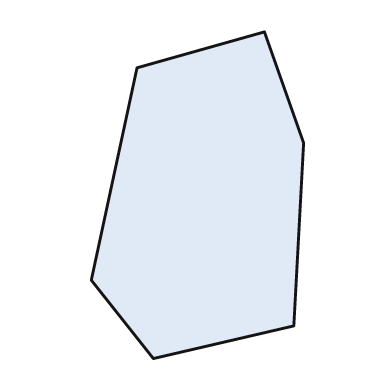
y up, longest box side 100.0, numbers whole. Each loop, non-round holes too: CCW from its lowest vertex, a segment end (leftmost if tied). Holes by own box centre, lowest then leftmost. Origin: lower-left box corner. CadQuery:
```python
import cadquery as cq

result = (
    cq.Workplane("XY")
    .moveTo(19.0, 0.0)
    .lineTo(62.0, 10.0)
    .lineTo(65.0, 66.0)
    .lineTo(53.0, 100.0)
    .lineTo(14.0, 89.0)
    .lineTo(0.0, 24.0)
    .close()
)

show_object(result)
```